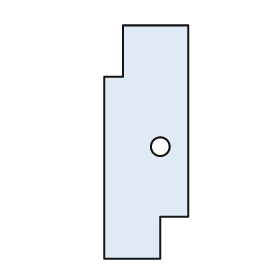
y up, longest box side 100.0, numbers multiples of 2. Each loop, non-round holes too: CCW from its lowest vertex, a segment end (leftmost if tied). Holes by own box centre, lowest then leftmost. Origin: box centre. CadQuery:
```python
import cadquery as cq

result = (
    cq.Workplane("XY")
    .moveTo(-18.0, -50.0)
    .lineTo(6.0, -50.0)
    .lineTo(6.0, -32.0)
    .lineTo(18.0, -32.0)
    .lineTo(18.0, 50.0)
    .lineTo(-10.0, 50.0)
    .lineTo(-10.0, 28.0)
    .lineTo(-18.0, 28.0)
    .close()
    .moveTo(6.0, -2.0)
    .circle(4.0)
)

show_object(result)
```